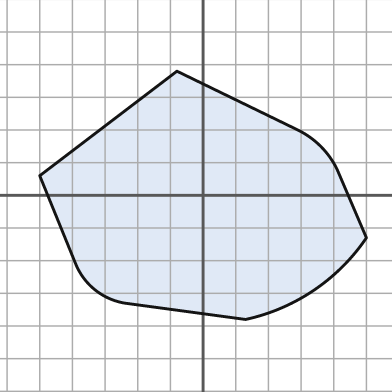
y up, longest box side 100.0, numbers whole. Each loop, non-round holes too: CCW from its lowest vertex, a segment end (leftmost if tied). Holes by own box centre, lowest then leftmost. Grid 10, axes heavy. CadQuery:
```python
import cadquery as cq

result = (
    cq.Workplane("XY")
    .moveTo(13.0, -38.0)
    .threePointArc((34.0, -29.0), (50.0, -13.0))
    .lineTo(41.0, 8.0)
    .threePointArc((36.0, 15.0), (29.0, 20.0))
    .lineTo(-8.0, 38.0)
    .lineTo(-50.0, 6.0)
    .lineTo(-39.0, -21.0)
    .threePointArc((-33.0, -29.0), (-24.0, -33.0))
    .close()
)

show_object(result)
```